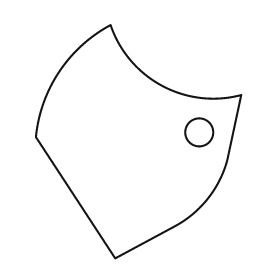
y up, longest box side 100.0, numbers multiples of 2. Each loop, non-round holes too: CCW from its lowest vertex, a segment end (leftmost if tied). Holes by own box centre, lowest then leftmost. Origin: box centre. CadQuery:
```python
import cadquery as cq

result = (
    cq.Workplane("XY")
    .moveTo(-10.0, -50.0)
    .lineTo(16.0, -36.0)
    .threePointArc((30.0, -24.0), (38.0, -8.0))
    .lineTo(44.0, 20.0)
    .threePointArc((10.0, 24.0), (-12.0, 50.0))
    .threePointArc((-34.0, 30.0), (-44.0, 2.0))
    .close()
    .moveTo(26.0, 4.0)
    .circle(6.0)
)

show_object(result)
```